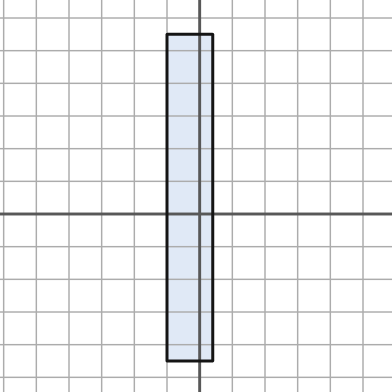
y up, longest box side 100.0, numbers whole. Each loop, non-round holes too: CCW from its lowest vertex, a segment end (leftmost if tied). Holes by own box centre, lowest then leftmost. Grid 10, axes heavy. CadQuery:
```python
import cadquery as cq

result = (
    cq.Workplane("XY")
    .moveTo(-10.0, -45.0)
    .lineTo(4.0, -45.0)
    .lineTo(4.0, 55.0)
    .lineTo(-10.0, 55.0)
    .close()
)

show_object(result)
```